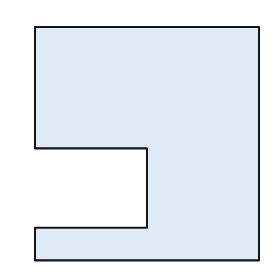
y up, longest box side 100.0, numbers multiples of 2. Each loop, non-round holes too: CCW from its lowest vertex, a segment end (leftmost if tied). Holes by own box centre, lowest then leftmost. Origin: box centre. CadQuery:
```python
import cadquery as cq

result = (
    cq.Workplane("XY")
    .moveTo(-48.0, -50.0)
    .lineTo(48.0, -50.0)
    .lineTo(48.0, 50.0)
    .lineTo(-48.0, 50.0)
    .lineTo(-48.0, -2.0)
    .lineTo(0.0, -2.0)
    .lineTo(0.0, -36.0)
    .lineTo(-48.0, -36.0)
    .close()
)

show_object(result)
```